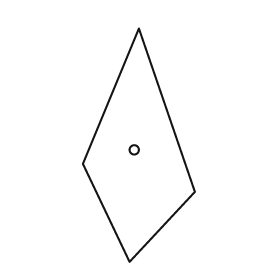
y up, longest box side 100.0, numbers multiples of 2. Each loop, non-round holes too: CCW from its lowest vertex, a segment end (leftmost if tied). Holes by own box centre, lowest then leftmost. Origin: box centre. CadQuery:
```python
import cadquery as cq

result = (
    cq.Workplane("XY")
    .moveTo(-4.0, -50.0)
    .lineTo(24.0, -20.0)
    .lineTo(0.0, 50.0)
    .lineTo(-24.0, -8.0)
    .close()
    .moveTo(-2.0, -2.0)
    .circle(2.0)
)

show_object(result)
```